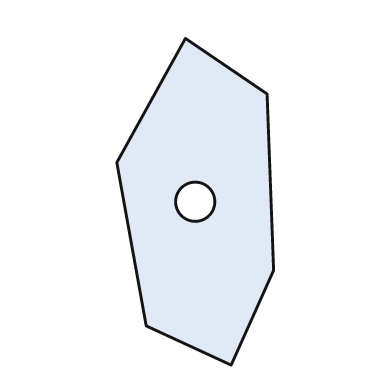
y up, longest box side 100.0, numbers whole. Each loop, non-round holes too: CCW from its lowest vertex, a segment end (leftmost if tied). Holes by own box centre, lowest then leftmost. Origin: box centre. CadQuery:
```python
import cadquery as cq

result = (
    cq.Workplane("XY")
    .moveTo(11.0, -50.0)
    .lineTo(24.0, -21.0)
    .lineTo(22.0, 33.0)
    .lineTo(-3.0, 50.0)
    .lineTo(-24.0, 12.0)
    .lineTo(-15.0, -38.0)
    .close()
    .moveTo(0.0, 0.0)
    .circle(6.0)
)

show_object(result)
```